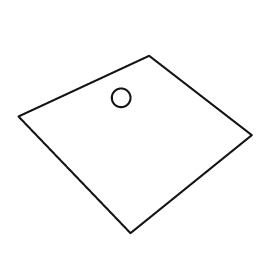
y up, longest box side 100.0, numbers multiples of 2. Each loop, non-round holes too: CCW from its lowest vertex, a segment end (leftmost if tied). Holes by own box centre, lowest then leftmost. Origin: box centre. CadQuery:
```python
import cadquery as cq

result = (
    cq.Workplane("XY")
    .moveTo(-2.0, -38.0)
    .lineTo(50.0, 4.0)
    .lineTo(6.0, 38.0)
    .lineTo(-50.0, 12.0)
    .close()
    .moveTo(-6.0, 20.0)
    .circle(4.0)
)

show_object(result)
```